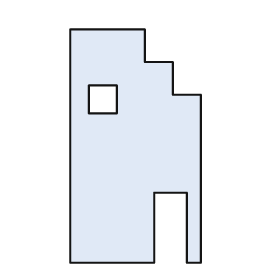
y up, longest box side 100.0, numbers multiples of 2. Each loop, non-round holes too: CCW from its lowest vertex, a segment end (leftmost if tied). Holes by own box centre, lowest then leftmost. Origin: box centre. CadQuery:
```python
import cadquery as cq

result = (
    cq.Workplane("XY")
    .moveTo(-28.0, -50.0)
    .lineTo(8.0, -50.0)
    .lineTo(8.0, -20.0)
    .lineTo(22.0, -20.0)
    .lineTo(22.0, -50.0)
    .lineTo(28.0, -50.0)
    .lineTo(28.0, 22.0)
    .lineTo(16.0, 22.0)
    .lineTo(16.0, 36.0)
    .lineTo(4.0, 36.0)
    .lineTo(4.0, 50.0)
    .lineTo(-28.0, 50.0)
    .close()
    .moveTo(-20.0, 14.0)
    .lineTo(-8.0, 14.0)
    .lineTo(-8.0, 26.0)
    .lineTo(-20.0, 26.0)
    .close()
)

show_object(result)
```